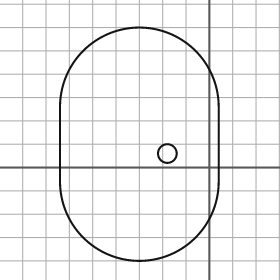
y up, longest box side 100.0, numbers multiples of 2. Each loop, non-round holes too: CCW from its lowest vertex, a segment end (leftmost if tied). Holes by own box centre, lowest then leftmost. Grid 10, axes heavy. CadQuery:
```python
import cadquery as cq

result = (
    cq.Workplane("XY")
    .moveTo(-64.0, -6.0)
    .threePointArc((-30.0, -40.0), (4.0, -6.0))
    .lineTo(4.0, 26.0)
    .threePointArc((-30.0, 60.0), (-64.0, 26.0))
    .close()
    .moveTo(-18.0, 6.0)
    .circle(4.0)
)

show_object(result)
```